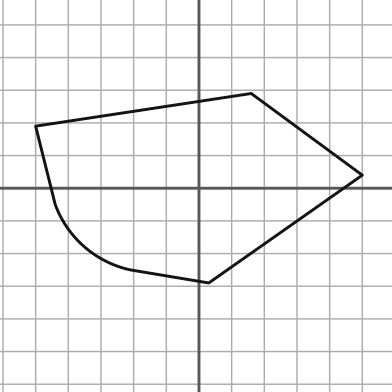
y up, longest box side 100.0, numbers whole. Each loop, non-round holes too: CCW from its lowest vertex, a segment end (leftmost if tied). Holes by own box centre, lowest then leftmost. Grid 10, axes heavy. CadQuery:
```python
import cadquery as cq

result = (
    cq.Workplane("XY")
    .moveTo(3.0, -29.0)
    .lineTo(50.0, 4.0)
    .lineTo(16.0, 29.0)
    .lineTo(-50.0, 19.0)
    .lineTo(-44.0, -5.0)
    .threePointArc((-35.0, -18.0), (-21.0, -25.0))
    .close()
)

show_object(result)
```